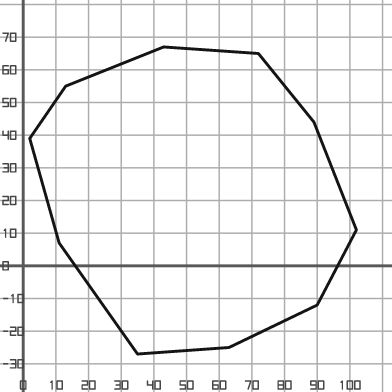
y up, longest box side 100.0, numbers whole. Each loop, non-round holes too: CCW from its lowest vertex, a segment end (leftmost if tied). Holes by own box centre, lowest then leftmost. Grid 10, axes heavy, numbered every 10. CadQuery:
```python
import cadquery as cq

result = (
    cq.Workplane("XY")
    .moveTo(35.0, -27.0)
    .lineTo(63.0, -25.0)
    .lineTo(90.0, -12.0)
    .lineTo(102.0, 11.0)
    .lineTo(89.0, 44.0)
    .lineTo(72.0, 65.0)
    .lineTo(43.0, 67.0)
    .lineTo(13.0, 55.0)
    .lineTo(2.0, 39.0)
    .lineTo(11.0, 7.0)
    .close()
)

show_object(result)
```